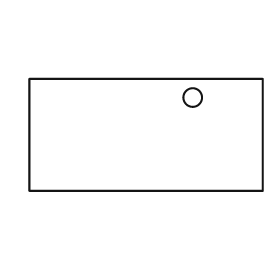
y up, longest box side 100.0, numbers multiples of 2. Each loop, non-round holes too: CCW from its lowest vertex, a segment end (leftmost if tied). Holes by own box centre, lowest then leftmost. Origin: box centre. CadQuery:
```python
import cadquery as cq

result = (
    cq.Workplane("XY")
    .moveTo(-50.0, -24.0)
    .lineTo(50.0, -24.0)
    .lineTo(50.0, 24.0)
    .lineTo(-50.0, 24.0)
    .close()
    .moveTo(20.0, 16.0)
    .circle(4.0)
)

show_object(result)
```